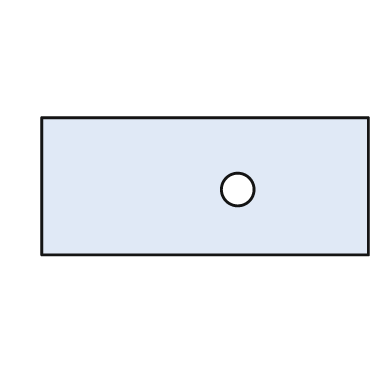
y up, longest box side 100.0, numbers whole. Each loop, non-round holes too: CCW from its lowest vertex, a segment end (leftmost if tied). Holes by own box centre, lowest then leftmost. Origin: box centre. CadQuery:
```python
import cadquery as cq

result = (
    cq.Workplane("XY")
    .moveTo(-50.0, -21.0)
    .lineTo(50.0, -21.0)
    .lineTo(50.0, 21.0)
    .lineTo(-50.0, 21.0)
    .close()
    .moveTo(10.0, -1.0)
    .circle(5.0)
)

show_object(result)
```